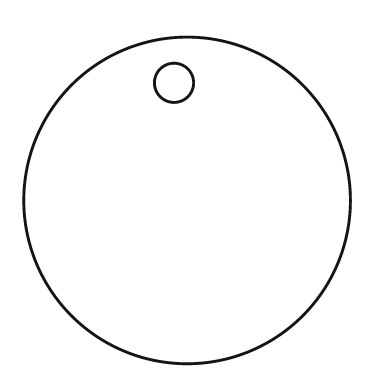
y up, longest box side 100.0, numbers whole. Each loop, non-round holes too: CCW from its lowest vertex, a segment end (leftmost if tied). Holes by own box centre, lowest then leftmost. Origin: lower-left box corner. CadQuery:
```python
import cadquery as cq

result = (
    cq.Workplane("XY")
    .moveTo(50.0, 50.0)
    .circle(50.0)
    .moveTo(46.0, 86.0)
    .circle(6.0)
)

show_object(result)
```